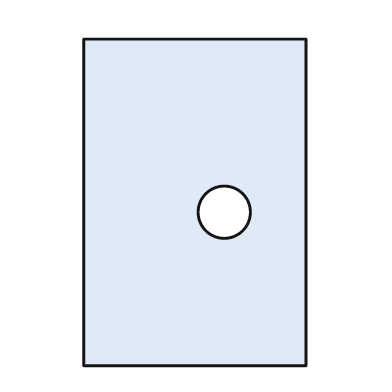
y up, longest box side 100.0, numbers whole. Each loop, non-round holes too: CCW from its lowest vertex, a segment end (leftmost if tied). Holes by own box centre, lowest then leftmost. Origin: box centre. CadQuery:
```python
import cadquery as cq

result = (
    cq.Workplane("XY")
    .moveTo(-34.0, -50.0)
    .lineTo(34.0, -50.0)
    .lineTo(34.0, 50.0)
    .lineTo(-34.0, 50.0)
    .close()
    .moveTo(9.0, -3.0)
    .circle(8.0)
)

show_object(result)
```